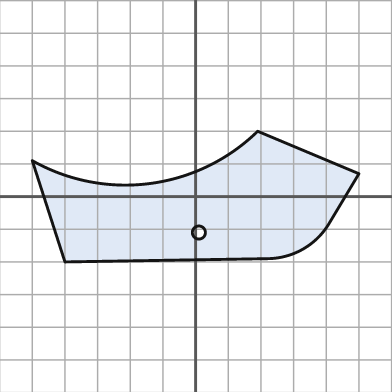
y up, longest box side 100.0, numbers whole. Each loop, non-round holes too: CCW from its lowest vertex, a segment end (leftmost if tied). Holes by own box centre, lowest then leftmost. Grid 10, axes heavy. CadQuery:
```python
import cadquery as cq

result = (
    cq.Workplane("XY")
    .moveTo(-40.0, -20.0)
    .lineTo(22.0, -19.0)
    .threePointArc((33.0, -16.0), (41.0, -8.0))
    .lineTo(50.0, 7.0)
    .lineTo(19.0, 20.0)
    .threePointArc((-14.0, 4.0), (-50.0, 11.0))
    .close()
    .moveTo(1.0, -11.0)
    .circle(2.0)
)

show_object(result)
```